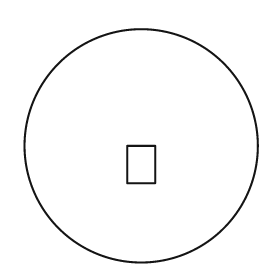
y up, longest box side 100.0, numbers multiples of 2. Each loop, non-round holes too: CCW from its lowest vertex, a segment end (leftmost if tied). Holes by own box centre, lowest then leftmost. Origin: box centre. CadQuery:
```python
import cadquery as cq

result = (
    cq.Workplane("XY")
    .moveTo(0.0, 0.0)
    .circle(50.0)
    .moveTo(-6.0, -16.0)
    .lineTo(6.0, -16.0)
    .lineTo(6.0, 0.0)
    .lineTo(-6.0, 0.0)
    .close()
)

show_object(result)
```